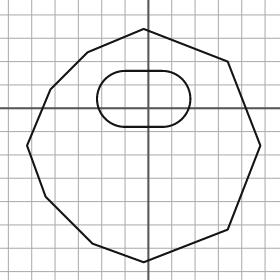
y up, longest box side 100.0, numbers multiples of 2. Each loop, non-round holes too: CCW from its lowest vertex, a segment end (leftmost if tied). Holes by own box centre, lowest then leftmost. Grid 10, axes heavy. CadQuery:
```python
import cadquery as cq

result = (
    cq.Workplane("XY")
    .moveTo(-2.0, -66.0)
    .lineTo(34.0, -52.0)
    .lineTo(48.0, -16.0)
    .lineTo(34.0, 20.0)
    .lineTo(-2.0, 34.0)
    .lineTo(-26.0, 24.0)
    .lineTo(-42.0, 8.0)
    .lineTo(-52.0, -16.0)
    .lineTo(-44.0, -38.0)
    .lineTo(-24.0, -58.0)
    .close()
    .moveTo(-10.0, -8.0)
    .lineTo(6.0, -8.0)
    .threePointArc((18.0, 4.0), (6.0, 16.0))
    .lineTo(-10.0, 16.0)
    .threePointArc((-22.0, 4.0), (-10.0, -8.0))
    .close()
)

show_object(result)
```